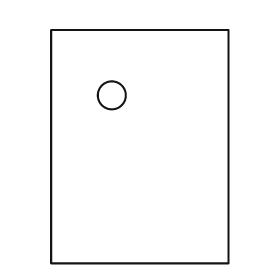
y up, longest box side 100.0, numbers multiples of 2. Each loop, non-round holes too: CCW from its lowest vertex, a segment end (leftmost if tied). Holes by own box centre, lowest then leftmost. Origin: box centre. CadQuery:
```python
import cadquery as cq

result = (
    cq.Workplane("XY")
    .moveTo(-38.0, -50.0)
    .lineTo(38.0, -50.0)
    .lineTo(38.0, 50.0)
    .lineTo(-38.0, 50.0)
    .close()
    .moveTo(-12.0, 22.0)
    .circle(6.0)
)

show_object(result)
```